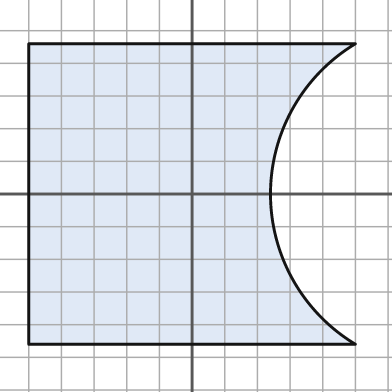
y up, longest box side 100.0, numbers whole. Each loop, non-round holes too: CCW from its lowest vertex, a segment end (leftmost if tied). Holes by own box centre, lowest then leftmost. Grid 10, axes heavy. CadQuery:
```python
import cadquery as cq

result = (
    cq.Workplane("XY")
    .moveTo(-50.0, -46.0)
    .lineTo(50.0, -46.0)
    .threePointArc((24.0, 0.0), (50.0, 46.0))
    .lineTo(-50.0, 46.0)
    .close()
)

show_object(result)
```